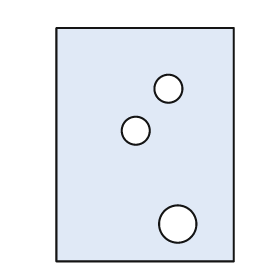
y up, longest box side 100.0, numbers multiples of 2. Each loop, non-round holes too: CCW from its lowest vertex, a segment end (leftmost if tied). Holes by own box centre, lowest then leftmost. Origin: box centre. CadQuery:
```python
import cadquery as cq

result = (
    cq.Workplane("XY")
    .moveTo(-38.0, -50.0)
    .lineTo(38.0, -50.0)
    .lineTo(38.0, 50.0)
    .lineTo(-38.0, 50.0)
    .close()
    .moveTo(14.0, -34.0)
    .circle(8.0)
    .moveTo(-4.0, 6.0)
    .circle(6.0)
    .moveTo(10.0, 24.0)
    .circle(6.0)
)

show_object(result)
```